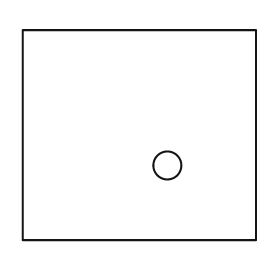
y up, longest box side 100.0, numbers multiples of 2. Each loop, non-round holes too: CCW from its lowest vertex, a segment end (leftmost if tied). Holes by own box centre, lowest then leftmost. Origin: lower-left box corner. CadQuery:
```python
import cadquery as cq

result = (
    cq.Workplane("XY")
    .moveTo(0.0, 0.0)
    .lineTo(100.0, 0.0)
    .lineTo(100.0, 90.0)
    .lineTo(0.0, 90.0)
    .close()
    .moveTo(62.0, 32.0)
    .circle(6.0)
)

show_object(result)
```